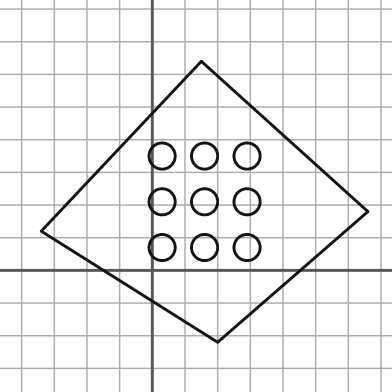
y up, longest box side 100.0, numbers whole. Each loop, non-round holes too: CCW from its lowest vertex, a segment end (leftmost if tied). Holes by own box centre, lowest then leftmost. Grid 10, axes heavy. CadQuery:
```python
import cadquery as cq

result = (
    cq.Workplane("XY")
    .moveTo(20.0, -22.0)
    .lineTo(66.0, 18.0)
    .lineTo(15.0, 64.0)
    .lineTo(-34.0, 12.0)
    .close()
    .moveTo(3.0, 7.0)
    .circle(4.0)
    .moveTo(16.0, 7.0)
    .circle(4.0)
    .moveTo(29.0, 7.0)
    .circle(4.0)
    .moveTo(3.0, 21.0)
    .circle(4.0)
    .moveTo(16.0, 21.0)
    .circle(4.0)
    .moveTo(29.0, 21.0)
    .circle(4.0)
    .moveTo(3.0, 35.0)
    .circle(4.0)
    .moveTo(16.0, 35.0)
    .circle(4.0)
    .moveTo(29.0, 35.0)
    .circle(4.0)
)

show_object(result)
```